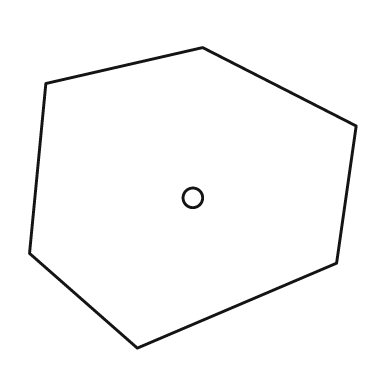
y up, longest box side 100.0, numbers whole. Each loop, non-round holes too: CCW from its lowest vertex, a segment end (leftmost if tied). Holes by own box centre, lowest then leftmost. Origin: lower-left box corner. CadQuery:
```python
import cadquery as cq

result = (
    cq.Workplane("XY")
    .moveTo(33.0, 0.0)
    .lineTo(94.0, 26.0)
    .lineTo(100.0, 68.0)
    .lineTo(53.0, 92.0)
    .lineTo(5.0, 81.0)
    .lineTo(0.0, 29.0)
    .close()
    .moveTo(50.0, 46.0)
    .circle(3.0)
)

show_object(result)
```